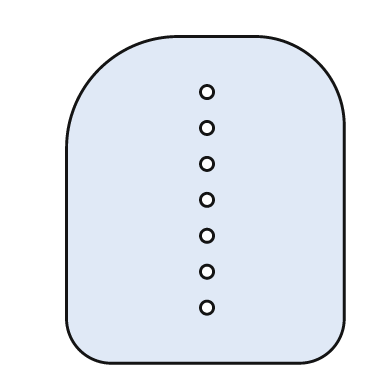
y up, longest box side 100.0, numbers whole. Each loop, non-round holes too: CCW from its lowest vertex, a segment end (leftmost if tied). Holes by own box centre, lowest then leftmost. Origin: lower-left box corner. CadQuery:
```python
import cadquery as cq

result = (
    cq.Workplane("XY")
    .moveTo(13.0, 0.0)
    .lineTo(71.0, 0.0)
    .threePointArc((81.0, 4.0), (85.0, 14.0))
    .lineTo(85.0, 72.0)
    .threePointArc((77.0, 92.0), (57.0, 100.0))
    .lineTo(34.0, 100.0)
    .threePointArc((10.0, 90.0), (0.0, 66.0))
    .lineTo(0.0, 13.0)
    .threePointArc((4.0, 4.0), (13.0, 0.0))
    .close()
    .moveTo(43.0, 17.0)
    .circle(2.0)
    .moveTo(43.0, 28.0)
    .circle(2.0)
    .moveTo(43.0, 39.0)
    .circle(2.0)
    .moveTo(43.0, 50.0)
    .circle(2.0)
    .moveTo(43.0, 61.0)
    .circle(2.0)
    .moveTo(43.0, 72.0)
    .circle(2.0)
    .moveTo(43.0, 83.0)
    .circle(2.0)
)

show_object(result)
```